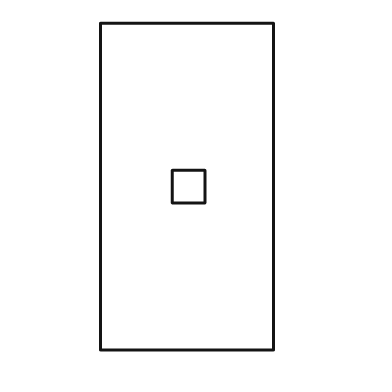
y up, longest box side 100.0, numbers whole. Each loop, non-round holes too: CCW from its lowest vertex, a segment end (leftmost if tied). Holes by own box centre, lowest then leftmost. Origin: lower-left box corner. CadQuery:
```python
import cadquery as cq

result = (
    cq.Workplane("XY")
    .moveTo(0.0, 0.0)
    .lineTo(53.0, 0.0)
    .lineTo(53.0, 100.0)
    .lineTo(0.0, 100.0)
    .close()
    .moveTo(22.0, 45.0)
    .lineTo(32.0, 45.0)
    .lineTo(32.0, 55.0)
    .lineTo(22.0, 55.0)
    .close()
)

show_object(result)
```